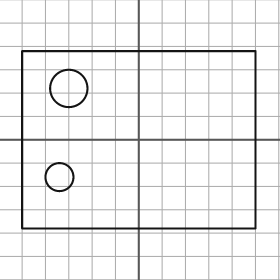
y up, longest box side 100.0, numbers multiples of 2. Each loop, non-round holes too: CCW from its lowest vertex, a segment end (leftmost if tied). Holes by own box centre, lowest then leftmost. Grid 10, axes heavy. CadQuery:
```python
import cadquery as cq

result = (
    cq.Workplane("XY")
    .moveTo(-50.0, -38.0)
    .lineTo(50.0, -38.0)
    .lineTo(50.0, 38.0)
    .lineTo(-50.0, 38.0)
    .close()
    .moveTo(-34.0, -16.0)
    .circle(6.0)
    .moveTo(-30.0, 22.0)
    .circle(8.0)
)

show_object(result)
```